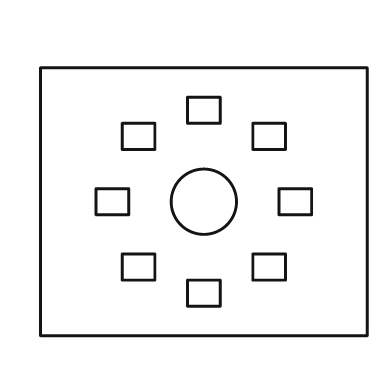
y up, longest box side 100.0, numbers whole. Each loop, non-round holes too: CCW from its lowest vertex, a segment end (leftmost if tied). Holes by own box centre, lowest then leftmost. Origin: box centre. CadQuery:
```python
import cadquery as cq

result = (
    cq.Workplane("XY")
    .moveTo(-50.0, -41.0)
    .lineTo(50.0, -41.0)
    .lineTo(50.0, 41.0)
    .lineTo(-50.0, 41.0)
    .close()
    .moveTo(-5.0, -32.0)
    .lineTo(5.0, -32.0)
    .lineTo(5.0, -24.0)
    .lineTo(-5.0, -24.0)
    .close()
    .moveTo(-25.0, -24.0)
    .lineTo(-15.0, -24.0)
    .lineTo(-15.0, -16.0)
    .lineTo(-25.0, -16.0)
    .close()
    .moveTo(15.0, -24.0)
    .lineTo(25.0, -24.0)
    .lineTo(25.0, -16.0)
    .lineTo(15.0, -16.0)
    .close()
    .moveTo(-33.0, -4.0)
    .lineTo(-23.0, -4.0)
    .lineTo(-23.0, 4.0)
    .lineTo(-33.0, 4.0)
    .close()
    .moveTo(0.0, 0.0)
    .circle(10.0)
    .moveTo(23.0, -4.0)
    .lineTo(33.0, -4.0)
    .lineTo(33.0, 4.0)
    .lineTo(23.0, 4.0)
    .close()
    .moveTo(-25.0, 16.0)
    .lineTo(-15.0, 16.0)
    .lineTo(-15.0, 24.0)
    .lineTo(-25.0, 24.0)
    .close()
    .moveTo(15.0, 16.0)
    .lineTo(25.0, 16.0)
    .lineTo(25.0, 24.0)
    .lineTo(15.0, 24.0)
    .close()
    .moveTo(-5.0, 24.0)
    .lineTo(5.0, 24.0)
    .lineTo(5.0, 32.0)
    .lineTo(-5.0, 32.0)
    .close()
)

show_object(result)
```